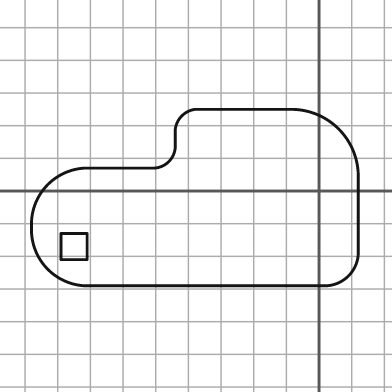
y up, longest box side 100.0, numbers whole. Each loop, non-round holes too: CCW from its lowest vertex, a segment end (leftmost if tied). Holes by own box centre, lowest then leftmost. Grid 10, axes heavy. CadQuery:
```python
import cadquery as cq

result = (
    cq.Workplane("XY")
    .moveTo(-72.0, -29.0)
    .lineTo(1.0, -29.0)
    .threePointArc((9.0, -26.0), (12.0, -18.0))
    .lineTo(12.0, 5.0)
    .threePointArc((6.0, 19.0), (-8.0, 25.0))
    .lineTo(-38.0, 25.0)
    .threePointArc((-42.0, 23.0), (-44.0, 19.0))
    .lineTo(-44.0, 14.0)
    .threePointArc((-46.0, 9.0), (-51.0, 7.0))
    .lineTo(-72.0, 7.0)
    .threePointArc((-83.0, 2.0), (-88.0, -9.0))
    .lineTo(-88.0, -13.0)
    .threePointArc((-83.0, -24.0), (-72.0, -29.0))
    .close()
    .moveTo(-79.0, -21.0)
    .lineTo(-71.0, -21.0)
    .lineTo(-71.0, -13.0)
    .lineTo(-79.0, -13.0)
    .close()
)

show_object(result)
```